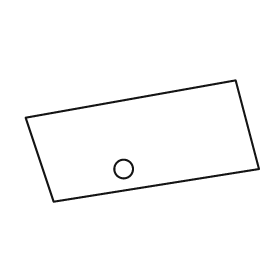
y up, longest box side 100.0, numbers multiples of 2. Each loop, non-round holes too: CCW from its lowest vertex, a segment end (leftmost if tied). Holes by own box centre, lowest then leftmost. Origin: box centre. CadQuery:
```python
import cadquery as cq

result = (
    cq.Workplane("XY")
    .moveTo(-38.0, -26.0)
    .lineTo(50.0, -12.0)
    .lineTo(40.0, 26.0)
    .lineTo(-50.0, 10.0)
    .close()
    .moveTo(-8.0, -12.0)
    .circle(4.0)
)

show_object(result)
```